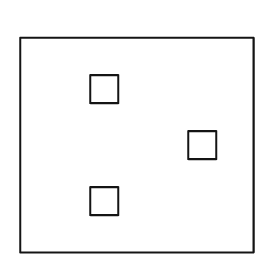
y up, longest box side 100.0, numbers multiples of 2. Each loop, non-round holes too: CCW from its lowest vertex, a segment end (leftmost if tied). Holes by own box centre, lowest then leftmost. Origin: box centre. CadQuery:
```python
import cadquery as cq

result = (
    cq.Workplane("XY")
    .moveTo(-50.0, -46.0)
    .lineTo(50.0, -46.0)
    .lineTo(50.0, 46.0)
    .lineTo(-50.0, 46.0)
    .close()
    .moveTo(-20.0, -30.0)
    .lineTo(-8.0, -30.0)
    .lineTo(-8.0, -18.0)
    .lineTo(-20.0, -18.0)
    .close()
    .moveTo(22.0, -6.0)
    .lineTo(34.0, -6.0)
    .lineTo(34.0, 6.0)
    .lineTo(22.0, 6.0)
    .close()
    .moveTo(-20.0, 18.0)
    .lineTo(-8.0, 18.0)
    .lineTo(-8.0, 30.0)
    .lineTo(-20.0, 30.0)
    .close()
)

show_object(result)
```